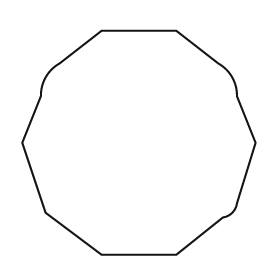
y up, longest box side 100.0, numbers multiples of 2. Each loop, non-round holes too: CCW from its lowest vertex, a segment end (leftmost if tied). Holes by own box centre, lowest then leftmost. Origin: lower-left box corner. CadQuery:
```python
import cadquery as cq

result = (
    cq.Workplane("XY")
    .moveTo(34.0, 0.0)
    .lineTo(66.0, 0.0)
    .lineTo(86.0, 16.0)
    .threePointArc((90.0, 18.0), (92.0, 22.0))
    .lineTo(100.0, 48.0)
    .lineTo(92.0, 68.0)
    .threePointArc((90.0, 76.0), (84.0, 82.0))
    .lineTo(66.0, 96.0)
    .lineTo(34.0, 96.0)
    .lineTo(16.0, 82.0)
    .threePointArc((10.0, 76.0), (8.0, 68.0))
    .lineTo(0.0, 48.0)
    .lineTo(10.0, 18.0)
    .close()
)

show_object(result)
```